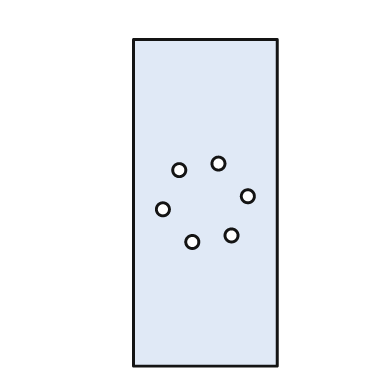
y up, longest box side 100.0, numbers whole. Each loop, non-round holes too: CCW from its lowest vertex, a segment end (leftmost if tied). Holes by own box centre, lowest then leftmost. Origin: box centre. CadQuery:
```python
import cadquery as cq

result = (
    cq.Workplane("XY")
    .moveTo(-22.0, -50.0)
    .lineTo(22.0, -50.0)
    .lineTo(22.0, 50.0)
    .lineTo(-22.0, 50.0)
    .close()
    .moveTo(-4.0, -12.0)
    .circle(2.0)
    .moveTo(8.0, -10.0)
    .circle(2.0)
    .moveTo(-13.0, -2.0)
    .circle(2.0)
    .moveTo(13.0, 2.0)
    .circle(2.0)
    .moveTo(-8.0, 10.0)
    .circle(2.0)
    .moveTo(4.0, 12.0)
    .circle(2.0)
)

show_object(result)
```